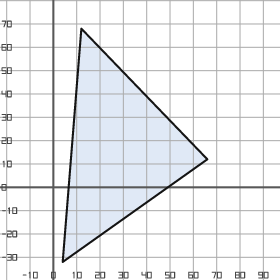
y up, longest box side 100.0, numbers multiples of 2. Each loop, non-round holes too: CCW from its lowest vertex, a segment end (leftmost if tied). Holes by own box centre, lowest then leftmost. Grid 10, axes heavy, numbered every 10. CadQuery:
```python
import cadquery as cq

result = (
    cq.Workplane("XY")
    .moveTo(4.0, -32.0)
    .lineTo(66.0, 12.0)
    .lineTo(12.0, 68.0)
    .close()
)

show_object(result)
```